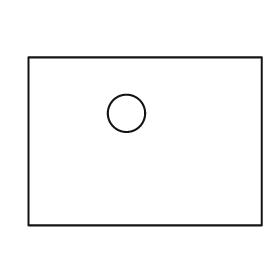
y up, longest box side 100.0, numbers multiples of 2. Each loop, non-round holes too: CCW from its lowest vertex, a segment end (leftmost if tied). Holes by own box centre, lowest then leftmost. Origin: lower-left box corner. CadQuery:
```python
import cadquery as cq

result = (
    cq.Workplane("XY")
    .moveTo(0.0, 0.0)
    .lineTo(100.0, 0.0)
    .lineTo(100.0, 72.0)
    .lineTo(0.0, 72.0)
    .close()
    .moveTo(42.0, 48.0)
    .circle(8.0)
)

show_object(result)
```